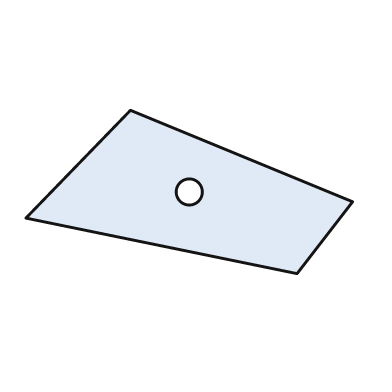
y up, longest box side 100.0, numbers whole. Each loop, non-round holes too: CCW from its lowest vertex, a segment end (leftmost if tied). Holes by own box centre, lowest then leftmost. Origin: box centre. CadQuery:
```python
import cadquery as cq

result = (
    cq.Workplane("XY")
    .moveTo(33.0, -25.0)
    .lineTo(50.0, -3.0)
    .lineTo(-18.0, 25.0)
    .lineTo(-50.0, -8.0)
    .close()
    .moveTo(0.0, 0.0)
    .circle(4.0)
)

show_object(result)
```